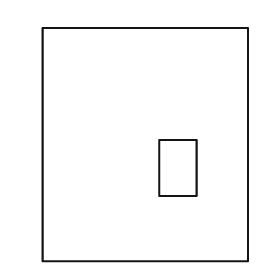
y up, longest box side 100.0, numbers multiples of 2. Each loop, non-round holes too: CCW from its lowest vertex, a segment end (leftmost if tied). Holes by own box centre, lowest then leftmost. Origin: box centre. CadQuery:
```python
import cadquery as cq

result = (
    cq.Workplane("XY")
    .moveTo(-44.0, -50.0)
    .lineTo(44.0, -50.0)
    .lineTo(44.0, 50.0)
    .lineTo(-44.0, 50.0)
    .close()
    .moveTo(6.0, -22.0)
    .lineTo(22.0, -22.0)
    .lineTo(22.0, 2.0)
    .lineTo(6.0, 2.0)
    .close()
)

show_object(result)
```